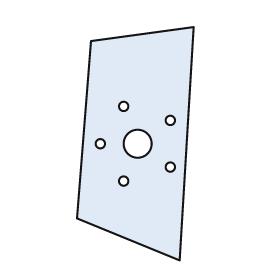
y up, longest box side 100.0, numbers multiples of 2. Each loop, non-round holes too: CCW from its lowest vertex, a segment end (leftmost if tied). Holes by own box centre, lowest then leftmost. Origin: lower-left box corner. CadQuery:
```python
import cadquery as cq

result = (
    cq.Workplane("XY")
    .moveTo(44.0, 0.0)
    .lineTo(50.0, 100.0)
    .lineTo(6.0, 94.0)
    .lineTo(0.0, 18.0)
    .close()
    .moveTo(20.0, 34.0)
    .circle(2.0)
    .moveTo(40.0, 40.0)
    .circle(2.0)
    .moveTo(10.0, 50.0)
    .circle(2.0)
    .moveTo(26.0, 50.0)
    .circle(6.0)
    .moveTo(40.0, 60.0)
    .circle(2.0)
    .moveTo(20.0, 66.0)
    .circle(2.0)
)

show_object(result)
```